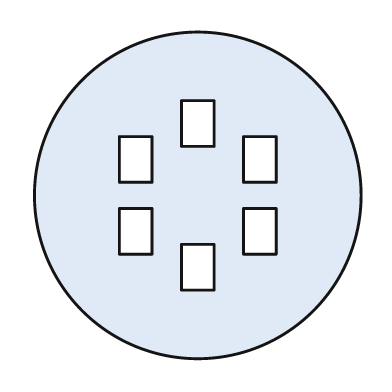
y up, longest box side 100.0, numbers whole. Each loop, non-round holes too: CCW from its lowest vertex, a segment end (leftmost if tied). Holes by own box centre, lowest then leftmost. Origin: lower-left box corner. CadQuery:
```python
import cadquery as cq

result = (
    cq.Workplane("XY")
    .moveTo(50.0, 50.0)
    .circle(50.0)
    .moveTo(45.0, 21.0)
    .lineTo(55.0, 21.0)
    .lineTo(55.0, 35.0)
    .lineTo(45.0, 35.0)
    .close()
    .moveTo(26.0, 32.0)
    .lineTo(36.0, 32.0)
    .lineTo(36.0, 46.0)
    .lineTo(26.0, 46.0)
    .close()
    .moveTo(64.0, 32.0)
    .lineTo(74.0, 32.0)
    .lineTo(74.0, 46.0)
    .lineTo(64.0, 46.0)
    .close()
    .moveTo(26.0, 54.0)
    .lineTo(36.0, 54.0)
    .lineTo(36.0, 68.0)
    .lineTo(26.0, 68.0)
    .close()
    .moveTo(64.0, 54.0)
    .lineTo(74.0, 54.0)
    .lineTo(74.0, 68.0)
    .lineTo(64.0, 68.0)
    .close()
    .moveTo(45.0, 65.0)
    .lineTo(55.0, 65.0)
    .lineTo(55.0, 79.0)
    .lineTo(45.0, 79.0)
    .close()
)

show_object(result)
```